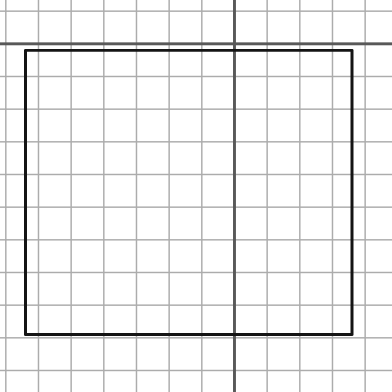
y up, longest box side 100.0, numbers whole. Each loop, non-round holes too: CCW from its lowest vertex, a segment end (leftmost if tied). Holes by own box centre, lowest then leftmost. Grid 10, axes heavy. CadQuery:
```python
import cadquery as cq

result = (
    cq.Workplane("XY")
    .moveTo(-64.0, -89.0)
    .lineTo(36.0, -89.0)
    .lineTo(36.0, -2.0)
    .lineTo(-64.0, -2.0)
    .close()
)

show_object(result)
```